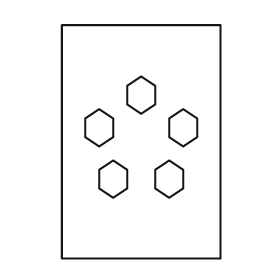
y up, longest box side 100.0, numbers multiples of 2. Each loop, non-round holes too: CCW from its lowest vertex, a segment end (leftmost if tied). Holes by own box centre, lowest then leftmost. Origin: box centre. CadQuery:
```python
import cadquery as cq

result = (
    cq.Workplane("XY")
    .moveTo(-34.0, -50.0)
    .lineTo(34.0, -50.0)
    .lineTo(34.0, 50.0)
    .lineTo(-34.0, 50.0)
    .close()
    .moveTo(-12.0, -24.0)
    .lineTo(-6.0, -20.0)
    .lineTo(-6.0, -12.0)
    .lineTo(-12.0, -8.0)
    .lineTo(-18.0, -12.0)
    .lineTo(-18.0, -20.0)
    .close()
    .moveTo(12.0, -24.0)
    .lineTo(18.0, -20.0)
    .lineTo(18.0, -12.0)
    .lineTo(12.0, -8.0)
    .lineTo(6.0, -12.0)
    .lineTo(6.0, -20.0)
    .close()
    .moveTo(-18.0, -2.0)
    .lineTo(-12.0, 2.0)
    .lineTo(-12.0, 10.0)
    .lineTo(-18.0, 14.0)
    .lineTo(-24.0, 10.0)
    .lineTo(-24.0, 2.0)
    .close()
    .moveTo(18.0, -2.0)
    .lineTo(24.0, 2.0)
    .lineTo(24.0, 10.0)
    .lineTo(18.0, 14.0)
    .lineTo(12.0, 10.0)
    .lineTo(12.0, 2.0)
    .close()
    .moveTo(0.0, 12.0)
    .lineTo(6.0, 16.0)
    .lineTo(6.0, 24.0)
    .lineTo(0.0, 28.0)
    .lineTo(-6.0, 24.0)
    .lineTo(-6.0, 16.0)
    .close()
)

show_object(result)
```